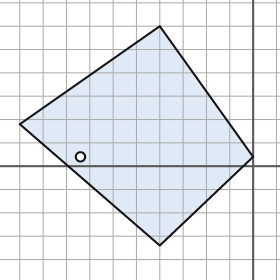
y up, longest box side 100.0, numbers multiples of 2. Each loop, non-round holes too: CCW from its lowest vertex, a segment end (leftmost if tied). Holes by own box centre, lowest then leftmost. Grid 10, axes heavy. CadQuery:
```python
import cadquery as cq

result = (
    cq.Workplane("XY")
    .moveTo(-40.0, -34.0)
    .lineTo(0.0, 4.0)
    .lineTo(-40.0, 60.0)
    .lineTo(-100.0, 18.0)
    .close()
    .moveTo(-74.0, 4.0)
    .circle(2.0)
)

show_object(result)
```